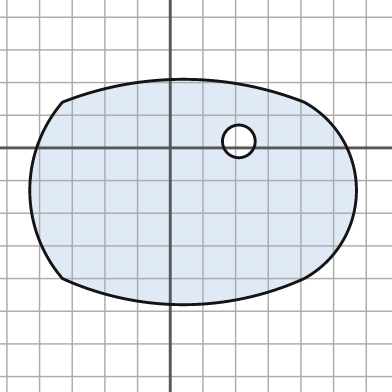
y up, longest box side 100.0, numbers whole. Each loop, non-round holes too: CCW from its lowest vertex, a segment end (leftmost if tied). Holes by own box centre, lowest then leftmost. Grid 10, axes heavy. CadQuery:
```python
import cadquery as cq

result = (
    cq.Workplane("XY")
    .moveTo(-33.0, -40.0)
    .threePointArc((4.0, -48.0), (41.0, -40.0))
    .threePointArc((57.0, -13.0), (41.0, 14.0))
    .threePointArc((4.0, 21.0), (-33.0, 14.0))
    .threePointArc((-43.0, -13.0), (-33.0, -40.0))
    .close()
    .moveTo(21.0, 2.0)
    .circle(5.0)
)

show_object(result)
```